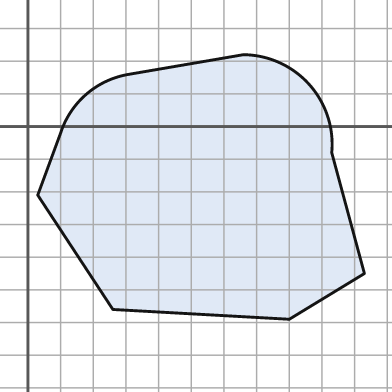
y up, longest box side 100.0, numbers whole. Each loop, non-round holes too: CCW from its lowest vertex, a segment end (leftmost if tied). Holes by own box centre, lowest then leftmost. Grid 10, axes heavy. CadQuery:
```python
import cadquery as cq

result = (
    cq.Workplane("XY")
    .moveTo(80.0, -59.0)
    .lineTo(103.0, -45.0)
    .lineTo(93.0, -8.0)
    .threePointArc((86.0, 13.0), (66.0, 22.0))
    .lineTo(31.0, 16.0)
    .threePointArc((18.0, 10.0), (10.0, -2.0))
    .lineTo(3.0, -21.0)
    .lineTo(26.0, -56.0)
    .close()
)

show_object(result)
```